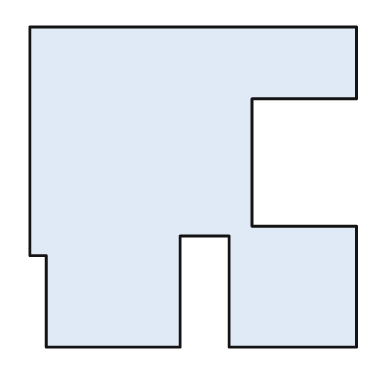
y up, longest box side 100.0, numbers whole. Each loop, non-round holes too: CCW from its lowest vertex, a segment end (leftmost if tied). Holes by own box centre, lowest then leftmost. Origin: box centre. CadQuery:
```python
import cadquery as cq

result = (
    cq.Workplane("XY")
    .moveTo(-45.0, -49.0)
    .lineTo(-4.0, -49.0)
    .lineTo(-4.0, -15.0)
    .lineTo(11.0, -15.0)
    .lineTo(11.0, -49.0)
    .lineTo(50.0, -49.0)
    .lineTo(50.0, -12.0)
    .lineTo(18.0, -12.0)
    .lineTo(18.0, 27.0)
    .lineTo(50.0, 27.0)
    .lineTo(50.0, 49.0)
    .lineTo(-50.0, 49.0)
    .lineTo(-50.0, -21.0)
    .lineTo(-45.0, -21.0)
    .close()
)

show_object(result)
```